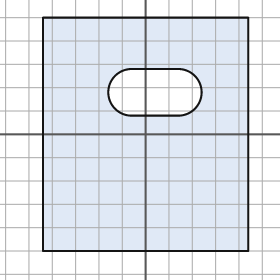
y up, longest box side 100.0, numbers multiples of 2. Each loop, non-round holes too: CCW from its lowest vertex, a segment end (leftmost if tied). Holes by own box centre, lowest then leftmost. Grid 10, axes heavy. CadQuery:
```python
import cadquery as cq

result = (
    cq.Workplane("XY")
    .moveTo(-44.0, -50.0)
    .lineTo(44.0, -50.0)
    .lineTo(44.0, 50.0)
    .lineTo(-44.0, 50.0)
    .close()
    .moveTo(-6.0, 8.0)
    .lineTo(14.0, 8.0)
    .threePointArc((24.0, 18.0), (14.0, 28.0))
    .lineTo(-6.0, 28.0)
    .threePointArc((-16.0, 18.0), (-6.0, 8.0))
    .close()
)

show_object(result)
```